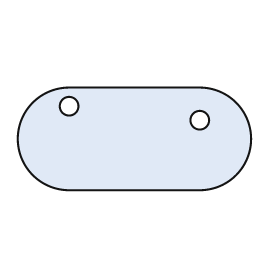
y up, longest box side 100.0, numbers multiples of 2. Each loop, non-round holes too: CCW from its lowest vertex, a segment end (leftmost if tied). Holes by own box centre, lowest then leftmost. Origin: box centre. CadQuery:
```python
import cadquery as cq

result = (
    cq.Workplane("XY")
    .moveTo(-28.0, -22.0)
    .lineTo(28.0, -22.0)
    .threePointArc((50.0, 0.0), (28.0, 22.0))
    .lineTo(-28.0, 22.0)
    .threePointArc((-50.0, 0.0), (-28.0, -22.0))
    .close()
    .moveTo(28.0, 8.0)
    .circle(4.0)
    .moveTo(-28.0, 14.0)
    .circle(4.0)
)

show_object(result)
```